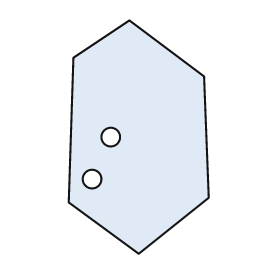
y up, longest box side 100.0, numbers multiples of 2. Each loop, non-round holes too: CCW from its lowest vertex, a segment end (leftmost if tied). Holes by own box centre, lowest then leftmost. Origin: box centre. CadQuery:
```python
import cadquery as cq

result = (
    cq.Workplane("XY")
    .moveTo(0.0, -50.0)
    .lineTo(30.0, -26.0)
    .lineTo(28.0, 26.0)
    .lineTo(-4.0, 50.0)
    .lineTo(-28.0, 34.0)
    .lineTo(-30.0, -28.0)
    .close()
    .moveTo(-20.0, -18.0)
    .circle(4.0)
    .moveTo(-12.0, 0.0)
    .circle(4.0)
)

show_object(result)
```